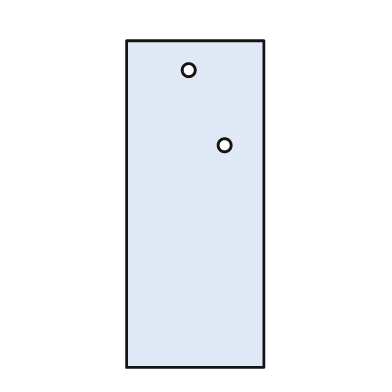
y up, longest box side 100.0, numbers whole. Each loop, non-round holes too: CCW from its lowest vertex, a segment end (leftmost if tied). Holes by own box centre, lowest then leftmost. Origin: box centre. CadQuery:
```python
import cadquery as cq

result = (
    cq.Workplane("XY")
    .moveTo(-21.0, -50.0)
    .lineTo(21.0, -50.0)
    .lineTo(21.0, 50.0)
    .lineTo(-21.0, 50.0)
    .close()
    .moveTo(9.0, 18.0)
    .circle(2.0)
    .moveTo(-2.0, 41.0)
    .circle(2.0)
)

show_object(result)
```